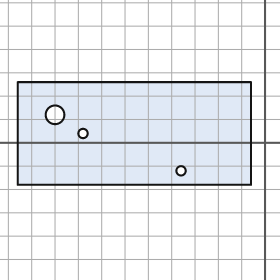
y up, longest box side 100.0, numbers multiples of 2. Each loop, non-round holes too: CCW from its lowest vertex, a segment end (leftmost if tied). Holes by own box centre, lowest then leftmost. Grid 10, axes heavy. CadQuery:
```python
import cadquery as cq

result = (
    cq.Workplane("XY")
    .moveTo(-106.0, -18.0)
    .lineTo(-6.0, -18.0)
    .lineTo(-6.0, 26.0)
    .lineTo(-106.0, 26.0)
    .close()
    .moveTo(-36.0, -12.0)
    .circle(2.0)
    .moveTo(-78.0, 4.0)
    .circle(2.0)
    .moveTo(-90.0, 12.0)
    .circle(4.0)
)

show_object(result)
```